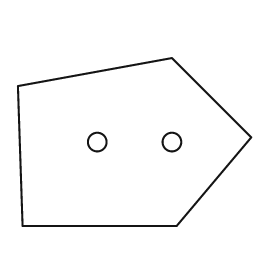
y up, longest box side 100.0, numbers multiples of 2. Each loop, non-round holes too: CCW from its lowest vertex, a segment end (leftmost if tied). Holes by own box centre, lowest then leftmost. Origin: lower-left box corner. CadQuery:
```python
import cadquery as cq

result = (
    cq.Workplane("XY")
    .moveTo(2.0, 0.0)
    .lineTo(68.0, 0.0)
    .lineTo(100.0, 38.0)
    .lineTo(66.0, 72.0)
    .lineTo(0.0, 60.0)
    .close()
    .moveTo(34.0, 36.0)
    .circle(4.0)
    .moveTo(66.0, 36.0)
    .circle(4.0)
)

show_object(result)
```